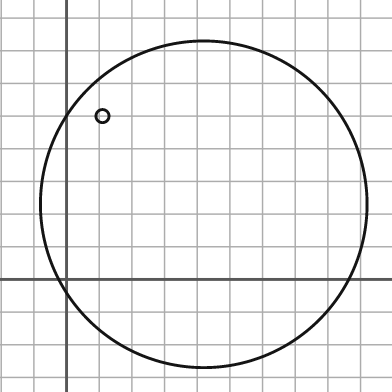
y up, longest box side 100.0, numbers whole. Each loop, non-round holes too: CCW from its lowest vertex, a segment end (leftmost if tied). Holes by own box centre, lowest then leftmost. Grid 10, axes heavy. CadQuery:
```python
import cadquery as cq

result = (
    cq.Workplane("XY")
    .moveTo(42.0, 23.0)
    .circle(50.0)
    .moveTo(11.0, 50.0)
    .circle(2.0)
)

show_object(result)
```